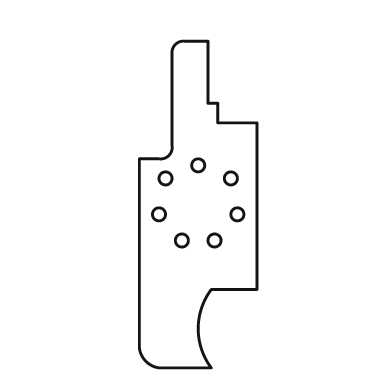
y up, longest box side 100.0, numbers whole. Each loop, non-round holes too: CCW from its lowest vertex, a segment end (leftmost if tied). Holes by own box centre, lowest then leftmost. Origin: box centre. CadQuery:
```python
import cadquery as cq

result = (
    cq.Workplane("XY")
    .moveTo(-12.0, -50.0)
    .lineTo(4.0, -50.0)
    .threePointArc((0.0, -38.0), (4.0, -26.0))
    .lineTo(18.0, -26.0)
    .lineTo(18.0, 25.0)
    .lineTo(6.0, 25.0)
    .lineTo(6.0, 31.0)
    .lineTo(3.0, 31.0)
    .lineTo(3.0, 50.0)
    .lineTo(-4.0, 50.0)
    .threePointArc((-7.0, 49.0), (-8.0, 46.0))
    .lineTo(-8.0, 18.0)
    .threePointArc((-9.0, 15.0), (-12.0, 14.0))
    .lineTo(-18.0, 14.0)
    .lineTo(-18.0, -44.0)
    .threePointArc((-16.0, -48.0), (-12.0, -50.0))
    .close()
    .moveTo(-5.0, -11.0)
    .circle(2.0)
    .moveTo(5.0, -11.0)
    .circle(2.0)
    .moveTo(-12.0, -3.0)
    .circle(2.0)
    .moveTo(12.0, -3.0)
    .circle(2.0)
    .moveTo(-10.0, 8.0)
    .circle(2.0)
    .moveTo(10.0, 8.0)
    .circle(2.0)
    .moveTo(0.0, 12.0)
    .circle(2.0)
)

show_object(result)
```